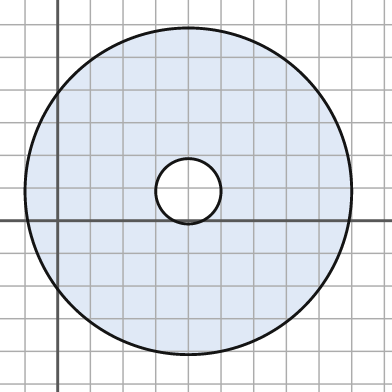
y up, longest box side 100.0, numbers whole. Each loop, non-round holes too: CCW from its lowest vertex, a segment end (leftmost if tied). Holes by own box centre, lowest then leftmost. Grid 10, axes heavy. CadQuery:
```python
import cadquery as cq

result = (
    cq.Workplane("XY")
    .moveTo(40.0, 9.0)
    .circle(50.0)
    .moveTo(40.0, 9.0)
    .circle(10.0)
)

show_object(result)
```